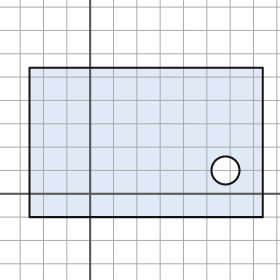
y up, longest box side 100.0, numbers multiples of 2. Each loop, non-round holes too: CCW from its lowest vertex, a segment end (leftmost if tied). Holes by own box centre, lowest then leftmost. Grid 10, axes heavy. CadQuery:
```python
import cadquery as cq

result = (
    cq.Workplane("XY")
    .moveTo(-26.0, -10.0)
    .lineTo(74.0, -10.0)
    .lineTo(74.0, 54.0)
    .lineTo(-26.0, 54.0)
    .close()
    .moveTo(58.0, 10.0)
    .circle(6.0)
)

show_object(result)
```